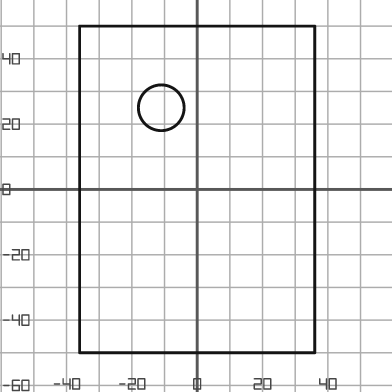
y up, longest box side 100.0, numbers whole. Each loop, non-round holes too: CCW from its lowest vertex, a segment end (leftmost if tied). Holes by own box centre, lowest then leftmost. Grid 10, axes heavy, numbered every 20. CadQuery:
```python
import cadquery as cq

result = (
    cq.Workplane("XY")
    .moveTo(-36.0, -50.0)
    .lineTo(36.0, -50.0)
    .lineTo(36.0, 50.0)
    .lineTo(-36.0, 50.0)
    .close()
    .moveTo(-11.0, 25.0)
    .circle(7.0)
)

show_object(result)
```